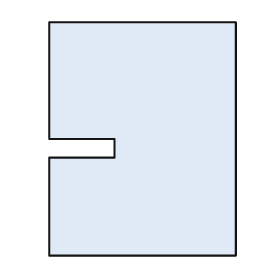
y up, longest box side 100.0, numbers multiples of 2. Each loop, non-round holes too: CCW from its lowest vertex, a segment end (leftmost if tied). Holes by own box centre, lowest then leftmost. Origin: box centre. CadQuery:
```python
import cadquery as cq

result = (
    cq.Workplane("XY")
    .moveTo(-40.0, -50.0)
    .lineTo(40.0, -50.0)
    .lineTo(40.0, 50.0)
    .lineTo(-40.0, 50.0)
    .lineTo(-40.0, 0.0)
    .lineTo(-12.0, 0.0)
    .lineTo(-12.0, -8.0)
    .lineTo(-40.0, -8.0)
    .close()
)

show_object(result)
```